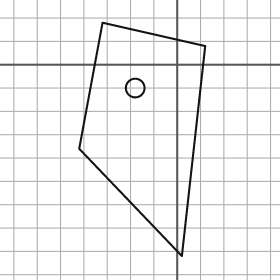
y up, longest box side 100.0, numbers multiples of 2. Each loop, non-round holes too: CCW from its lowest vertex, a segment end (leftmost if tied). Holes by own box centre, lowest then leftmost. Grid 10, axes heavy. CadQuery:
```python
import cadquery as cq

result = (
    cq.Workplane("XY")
    .moveTo(2.0, -82.0)
    .lineTo(12.0, 8.0)
    .lineTo(-32.0, 18.0)
    .lineTo(-42.0, -36.0)
    .close()
    .moveTo(-18.0, -10.0)
    .circle(4.0)
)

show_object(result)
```